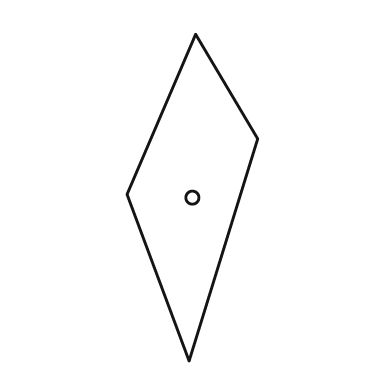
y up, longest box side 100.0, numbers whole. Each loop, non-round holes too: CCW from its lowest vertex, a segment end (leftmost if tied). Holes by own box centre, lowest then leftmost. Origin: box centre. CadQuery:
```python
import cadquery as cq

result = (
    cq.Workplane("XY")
    .moveTo(-1.0, -50.0)
    .lineTo(20.0, 18.0)
    .lineTo(1.0, 50.0)
    .lineTo(-20.0, 1.0)
    .close()
    .moveTo(0.0, 0.0)
    .circle(2.0)
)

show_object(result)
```